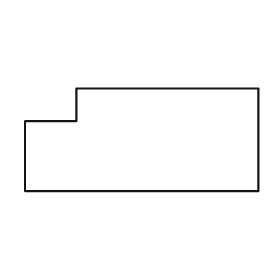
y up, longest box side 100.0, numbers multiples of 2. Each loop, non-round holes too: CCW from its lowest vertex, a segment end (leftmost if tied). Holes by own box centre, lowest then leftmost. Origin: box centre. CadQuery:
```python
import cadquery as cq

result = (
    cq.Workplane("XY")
    .moveTo(-50.0, -22.0)
    .lineTo(50.0, -22.0)
    .lineTo(50.0, 22.0)
    .lineTo(-28.0, 22.0)
    .lineTo(-28.0, 8.0)
    .lineTo(-50.0, 8.0)
    .close()
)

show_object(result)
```